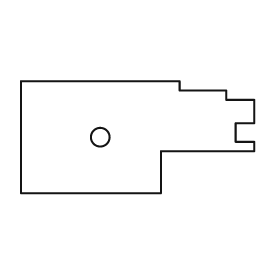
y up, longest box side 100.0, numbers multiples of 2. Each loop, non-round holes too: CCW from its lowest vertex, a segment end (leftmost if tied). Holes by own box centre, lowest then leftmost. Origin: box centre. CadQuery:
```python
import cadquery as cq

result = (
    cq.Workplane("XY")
    .moveTo(-50.0, -24.0)
    .lineTo(10.0, -24.0)
    .lineTo(10.0, -6.0)
    .lineTo(50.0, -6.0)
    .lineTo(50.0, -2.0)
    .lineTo(42.0, -2.0)
    .lineTo(42.0, 6.0)
    .lineTo(50.0, 6.0)
    .lineTo(50.0, 16.0)
    .lineTo(38.0, 16.0)
    .lineTo(38.0, 20.0)
    .lineTo(18.0, 20.0)
    .lineTo(18.0, 24.0)
    .lineTo(-50.0, 24.0)
    .close()
    .moveTo(-16.0, 0.0)
    .circle(4.0)
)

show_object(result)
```